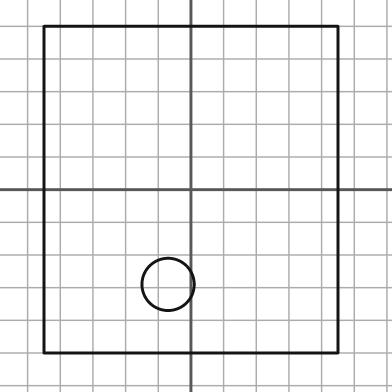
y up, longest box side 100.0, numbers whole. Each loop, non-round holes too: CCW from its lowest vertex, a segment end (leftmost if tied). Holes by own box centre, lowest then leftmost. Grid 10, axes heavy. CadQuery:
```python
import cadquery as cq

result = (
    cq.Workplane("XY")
    .moveTo(-45.0, -50.0)
    .lineTo(45.0, -50.0)
    .lineTo(45.0, 50.0)
    .lineTo(-45.0, 50.0)
    .close()
    .moveTo(-7.0, -29.0)
    .circle(8.0)
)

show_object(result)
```